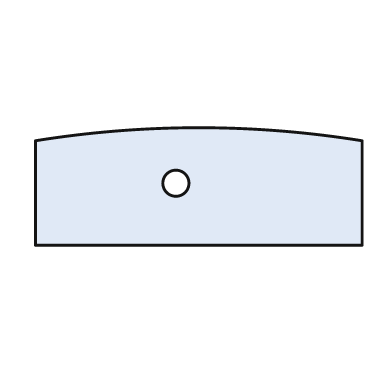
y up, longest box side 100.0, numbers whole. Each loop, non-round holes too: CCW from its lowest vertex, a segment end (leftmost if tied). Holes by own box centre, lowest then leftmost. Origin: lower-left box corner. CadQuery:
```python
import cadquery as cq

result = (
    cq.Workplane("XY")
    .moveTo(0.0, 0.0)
    .lineTo(100.0, 0.0)
    .lineTo(100.0, 32.0)
    .threePointArc((50.0, 36.0), (0.0, 32.0))
    .close()
    .moveTo(43.0, 19.0)
    .circle(4.0)
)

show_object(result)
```